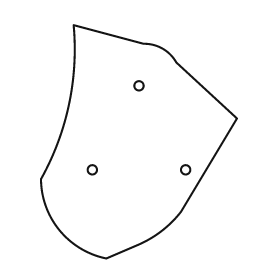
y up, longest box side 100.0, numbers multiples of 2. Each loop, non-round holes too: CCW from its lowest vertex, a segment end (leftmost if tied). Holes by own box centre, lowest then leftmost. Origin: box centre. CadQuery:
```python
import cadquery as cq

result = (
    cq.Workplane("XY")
    .moveTo(-14.0, -50.0)
    .lineTo(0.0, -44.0)
    .threePointArc((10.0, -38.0), (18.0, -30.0))
    .lineTo(42.0, 10.0)
    .lineTo(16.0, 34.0)
    .threePointArc((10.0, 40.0), (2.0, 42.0))
    .lineTo(-28.0, 50.0)
    .threePointArc((-30.0, 16.0), (-42.0, -16.0))
    .threePointArc((-34.0, -38.0), (-14.0, -50.0))
    .close()
    .moveTo(-20.0, -12.0)
    .circle(2.0)
    .moveTo(20.0, -12.0)
    .circle(2.0)
    .moveTo(0.0, 24.0)
    .circle(2.0)
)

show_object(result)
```